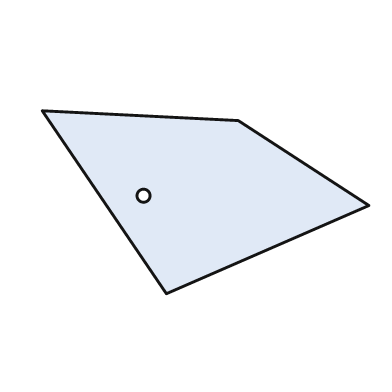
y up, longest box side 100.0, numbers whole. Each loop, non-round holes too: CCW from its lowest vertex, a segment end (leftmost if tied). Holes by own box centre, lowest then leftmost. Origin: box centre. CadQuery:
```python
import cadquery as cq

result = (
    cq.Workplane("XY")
    .moveTo(-12.0, -28.0)
    .lineTo(50.0, -1.0)
    .lineTo(10.0, 25.0)
    .lineTo(-50.0, 28.0)
    .close()
    .moveTo(-19.0, 2.0)
    .circle(2.0)
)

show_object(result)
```